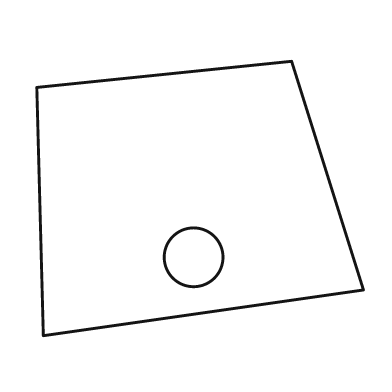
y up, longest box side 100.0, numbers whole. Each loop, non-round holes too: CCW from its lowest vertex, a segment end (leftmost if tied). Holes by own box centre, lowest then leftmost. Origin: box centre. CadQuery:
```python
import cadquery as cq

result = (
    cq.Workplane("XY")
    .moveTo(-48.0, -42.0)
    .lineTo(50.0, -28.0)
    .lineTo(28.0, 42.0)
    .lineTo(-50.0, 34.0)
    .close()
    .moveTo(-2.0, -18.0)
    .circle(9.0)
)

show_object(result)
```